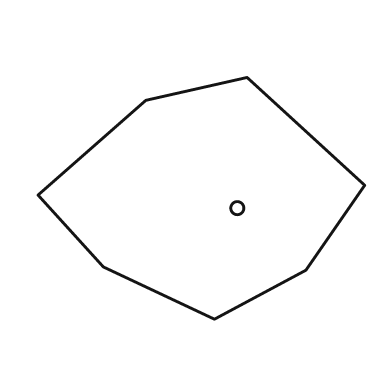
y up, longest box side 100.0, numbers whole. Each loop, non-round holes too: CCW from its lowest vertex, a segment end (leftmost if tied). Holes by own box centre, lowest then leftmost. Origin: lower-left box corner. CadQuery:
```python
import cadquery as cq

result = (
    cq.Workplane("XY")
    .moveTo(54.0, 0.0)
    .lineTo(82.0, 15.0)
    .lineTo(100.0, 41.0)
    .lineTo(64.0, 74.0)
    .lineTo(33.0, 67.0)
    .lineTo(0.0, 38.0)
    .lineTo(20.0, 16.0)
    .close()
    .moveTo(61.0, 34.0)
    .circle(2.0)
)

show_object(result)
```